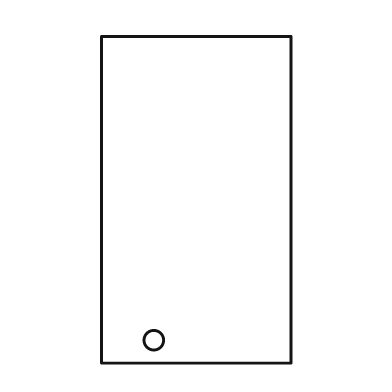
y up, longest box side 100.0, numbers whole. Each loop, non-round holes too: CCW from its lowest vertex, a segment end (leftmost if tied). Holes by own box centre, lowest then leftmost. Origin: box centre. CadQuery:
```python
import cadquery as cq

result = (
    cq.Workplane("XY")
    .moveTo(-29.0, -50.0)
    .lineTo(29.0, -50.0)
    .lineTo(29.0, 50.0)
    .lineTo(-29.0, 50.0)
    .close()
    .moveTo(-13.0, -43.0)
    .circle(3.0)
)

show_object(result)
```